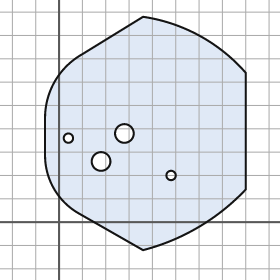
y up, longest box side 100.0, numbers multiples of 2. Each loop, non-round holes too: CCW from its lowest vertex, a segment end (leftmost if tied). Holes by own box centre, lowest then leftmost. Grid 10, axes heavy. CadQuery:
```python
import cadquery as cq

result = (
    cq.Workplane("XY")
    .moveTo(36.0, -12.0)
    .threePointArc((60.0, -2.0), (80.0, 14.0))
    .lineTo(80.0, 64.0)
    .threePointArc((60.0, 80.0), (36.0, 88.0))
    .lineTo(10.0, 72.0)
    .threePointArc((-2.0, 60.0), (-6.0, 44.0))
    .lineTo(-6.0, 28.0)
    .threePointArc((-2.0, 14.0), (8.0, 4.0))
    .close()
    .moveTo(48.0, 20.0)
    .circle(2.0)
    .moveTo(18.0, 26.0)
    .circle(4.0)
    .moveTo(4.0, 36.0)
    .circle(2.0)
    .moveTo(28.0, 38.0)
    .circle(4.0)
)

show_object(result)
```